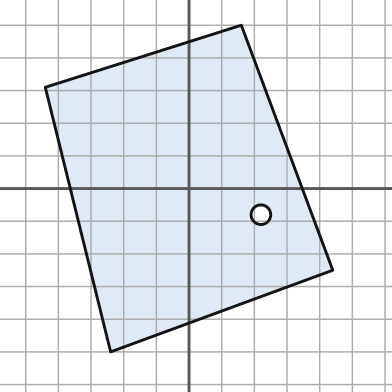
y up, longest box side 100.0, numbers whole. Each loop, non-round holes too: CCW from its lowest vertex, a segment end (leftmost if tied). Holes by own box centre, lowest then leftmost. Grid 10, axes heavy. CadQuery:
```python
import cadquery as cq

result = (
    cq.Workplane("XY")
    .moveTo(-24.0, -50.0)
    .lineTo(44.0, -25.0)
    .lineTo(16.0, 50.0)
    .lineTo(-44.0, 31.0)
    .close()
    .moveTo(22.0, -8.0)
    .circle(3.0)
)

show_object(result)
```